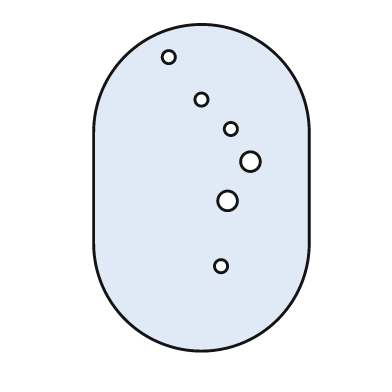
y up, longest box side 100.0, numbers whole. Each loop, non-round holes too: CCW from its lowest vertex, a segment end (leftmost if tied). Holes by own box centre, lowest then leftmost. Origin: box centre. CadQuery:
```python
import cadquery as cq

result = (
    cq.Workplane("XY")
    .moveTo(-33.0, -17.0)
    .threePointArc((0.0, -50.0), (33.0, -17.0))
    .lineTo(33.0, 17.0)
    .threePointArc((0.0, 50.0), (-33.0, 17.0))
    .close()
    .moveTo(6.0, -24.0)
    .circle(2.0)
    .moveTo(8.0, -4.0)
    .circle(3.0)
    .moveTo(15.0, 8.0)
    .circle(3.0)
    .moveTo(9.0, 18.0)
    .circle(2.0)
    .moveTo(0.0, 27.0)
    .circle(2.0)
    .moveTo(-10.0, 40.0)
    .circle(2.0)
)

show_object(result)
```